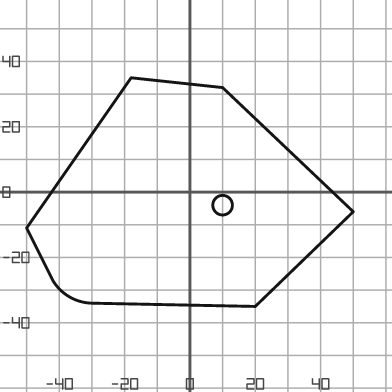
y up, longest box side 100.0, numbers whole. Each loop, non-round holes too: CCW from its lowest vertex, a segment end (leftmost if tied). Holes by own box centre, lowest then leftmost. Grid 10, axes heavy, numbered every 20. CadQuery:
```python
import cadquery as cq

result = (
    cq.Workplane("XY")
    .moveTo(20.0, -35.0)
    .lineTo(50.0, -6.0)
    .lineTo(10.0, 32.0)
    .lineTo(-18.0, 35.0)
    .lineTo(-50.0, -11.0)
    .lineTo(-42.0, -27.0)
    .threePointArc((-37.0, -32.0), (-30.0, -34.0))
    .close()
    .moveTo(10.0, -4.0)
    .circle(3.0)
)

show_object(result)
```